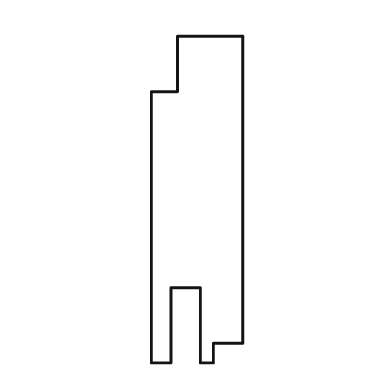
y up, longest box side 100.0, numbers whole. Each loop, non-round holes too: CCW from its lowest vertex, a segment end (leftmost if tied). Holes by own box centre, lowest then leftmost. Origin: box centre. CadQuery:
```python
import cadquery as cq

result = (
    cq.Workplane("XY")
    .moveTo(-14.0, -50.0)
    .lineTo(-8.0, -50.0)
    .lineTo(-8.0, -27.0)
    .lineTo(1.0, -27.0)
    .lineTo(1.0, -50.0)
    .lineTo(5.0, -50.0)
    .lineTo(5.0, -44.0)
    .lineTo(14.0, -44.0)
    .lineTo(14.0, 50.0)
    .lineTo(-6.0, 50.0)
    .lineTo(-6.0, 33.0)
    .lineTo(-14.0, 33.0)
    .close()
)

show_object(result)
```